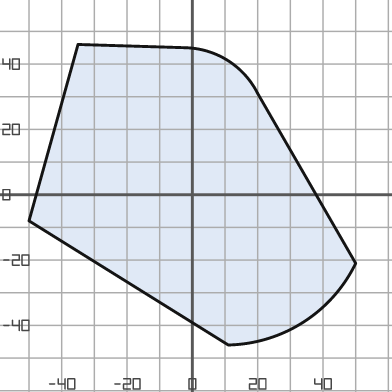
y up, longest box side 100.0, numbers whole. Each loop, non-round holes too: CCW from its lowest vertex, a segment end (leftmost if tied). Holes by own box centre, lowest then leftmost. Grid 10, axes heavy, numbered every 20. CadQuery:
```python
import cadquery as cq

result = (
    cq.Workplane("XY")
    .moveTo(11.0, -46.0)
    .threePointArc((34.0, -39.0), (50.0, -21.0))
    .lineTo(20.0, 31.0)
    .threePointArc((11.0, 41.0), (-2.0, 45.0))
    .lineTo(-35.0, 46.0)
    .lineTo(-50.0, -8.0)
    .close()
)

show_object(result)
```